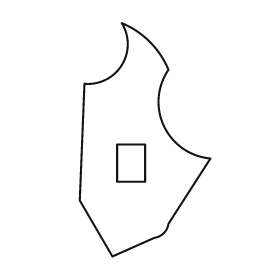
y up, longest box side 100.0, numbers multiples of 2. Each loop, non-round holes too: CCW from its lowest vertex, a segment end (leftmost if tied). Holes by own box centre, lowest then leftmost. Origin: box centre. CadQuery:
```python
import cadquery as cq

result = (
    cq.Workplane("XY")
    .moveTo(-14.0, -50.0)
    .lineTo(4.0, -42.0)
    .threePointArc((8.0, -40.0), (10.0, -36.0))
    .lineTo(28.0, -8.0)
    .threePointArc((8.0, 6.0), (10.0, 30.0))
    .threePointArc((2.0, 42.0), (-10.0, 50.0))
    .threePointArc((-10.0, 32.0), (-26.0, 24.0))
    .lineTo(-28.0, -26.0)
    .close()
    .moveTo(-12.0, -18.0)
    .lineTo(0.0, -18.0)
    .lineTo(0.0, -2.0)
    .lineTo(-12.0, -2.0)
    .close()
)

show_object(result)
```